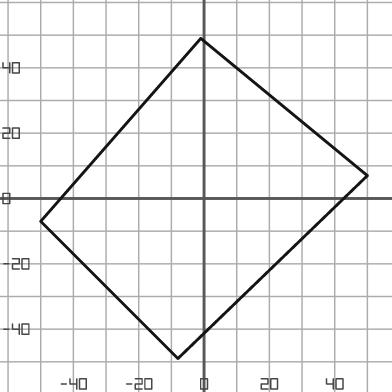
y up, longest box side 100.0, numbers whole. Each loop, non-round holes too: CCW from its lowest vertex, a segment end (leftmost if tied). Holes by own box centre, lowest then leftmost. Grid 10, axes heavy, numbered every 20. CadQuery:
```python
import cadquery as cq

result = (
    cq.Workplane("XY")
    .moveTo(-8.0, -49.0)
    .lineTo(50.0, 7.0)
    .lineTo(-1.0, 49.0)
    .lineTo(-50.0, -7.0)
    .close()
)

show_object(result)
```